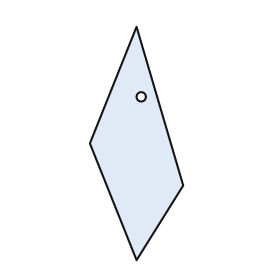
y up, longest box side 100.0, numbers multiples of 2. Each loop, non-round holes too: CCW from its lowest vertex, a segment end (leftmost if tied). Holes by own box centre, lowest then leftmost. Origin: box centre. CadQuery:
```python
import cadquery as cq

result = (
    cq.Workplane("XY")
    .moveTo(0.0, -50.0)
    .lineTo(20.0, -18.0)
    .lineTo(0.0, 50.0)
    .lineTo(-20.0, 0.0)
    .close()
    .moveTo(2.0, 20.0)
    .circle(2.0)
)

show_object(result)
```